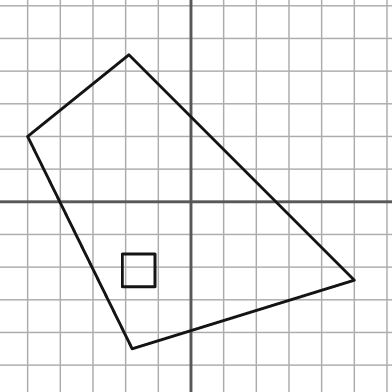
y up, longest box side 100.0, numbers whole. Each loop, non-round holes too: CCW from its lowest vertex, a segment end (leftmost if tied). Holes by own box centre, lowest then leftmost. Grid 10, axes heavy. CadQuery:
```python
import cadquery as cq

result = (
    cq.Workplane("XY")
    .moveTo(-18.0, -45.0)
    .lineTo(50.0, -24.0)
    .lineTo(-19.0, 45.0)
    .lineTo(-50.0, 20.0)
    .close()
    .moveTo(-21.0, -26.0)
    .lineTo(-11.0, -26.0)
    .lineTo(-11.0, -16.0)
    .lineTo(-21.0, -16.0)
    .close()
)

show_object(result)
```